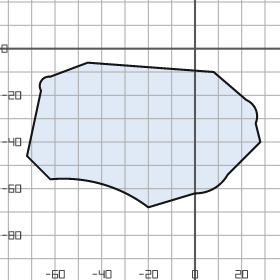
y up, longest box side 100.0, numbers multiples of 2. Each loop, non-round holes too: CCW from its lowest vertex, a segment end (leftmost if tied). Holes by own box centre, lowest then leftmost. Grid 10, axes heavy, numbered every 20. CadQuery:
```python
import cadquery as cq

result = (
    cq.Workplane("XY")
    .moveTo(-20.0, -68.0)
    .lineTo(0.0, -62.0)
    .threePointArc((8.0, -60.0), (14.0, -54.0))
    .lineTo(28.0, -40.0)
    .lineTo(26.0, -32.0)
    .threePointArc((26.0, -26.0), (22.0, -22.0))
    .lineTo(8.0, -10.0)
    .lineTo(-46.0, -6.0)
    .lineTo(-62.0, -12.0)
    .threePointArc((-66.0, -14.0), (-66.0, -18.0))
    .lineTo(-72.0, -46.0)
    .lineTo(-62.0, -56.0)
    .threePointArc((-40.0, -58.0), (-20.0, -68.0))
    .close()
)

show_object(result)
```